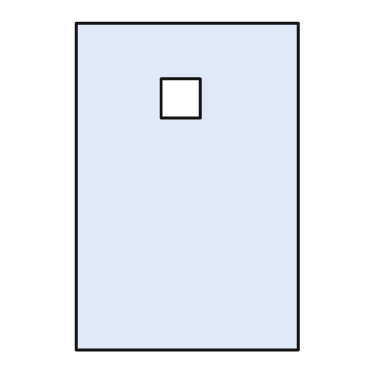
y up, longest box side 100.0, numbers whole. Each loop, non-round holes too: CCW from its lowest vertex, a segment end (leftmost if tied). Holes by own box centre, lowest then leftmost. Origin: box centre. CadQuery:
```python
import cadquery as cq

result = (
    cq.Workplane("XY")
    .moveTo(-34.0, -50.0)
    .lineTo(34.0, -50.0)
    .lineTo(34.0, 50.0)
    .lineTo(-34.0, 50.0)
    .close()
    .moveTo(-8.0, 21.0)
    .lineTo(4.0, 21.0)
    .lineTo(4.0, 33.0)
    .lineTo(-8.0, 33.0)
    .close()
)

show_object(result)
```